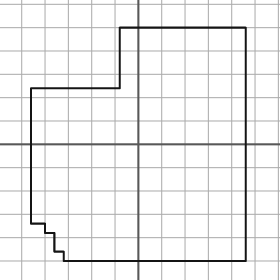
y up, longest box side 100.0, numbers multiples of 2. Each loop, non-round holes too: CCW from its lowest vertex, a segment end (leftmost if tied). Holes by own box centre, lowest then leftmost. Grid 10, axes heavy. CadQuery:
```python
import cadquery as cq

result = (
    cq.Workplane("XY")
    .moveTo(-32.0, -50.0)
    .lineTo(46.0, -50.0)
    .lineTo(46.0, 50.0)
    .lineTo(-8.0, 50.0)
    .lineTo(-8.0, 24.0)
    .lineTo(-46.0, 24.0)
    .lineTo(-46.0, -34.0)
    .lineTo(-40.0, -34.0)
    .lineTo(-40.0, -38.0)
    .lineTo(-36.0, -38.0)
    .lineTo(-36.0, -46.0)
    .lineTo(-32.0, -46.0)
    .close()
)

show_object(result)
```